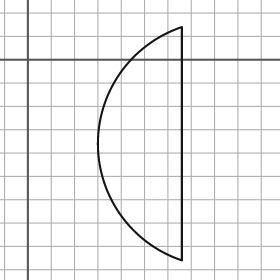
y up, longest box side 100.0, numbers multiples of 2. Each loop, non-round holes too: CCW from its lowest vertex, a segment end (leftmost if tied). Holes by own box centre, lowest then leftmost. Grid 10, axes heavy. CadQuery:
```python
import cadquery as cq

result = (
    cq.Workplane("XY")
    .moveTo(66.0, -86.0)
    .lineTo(66.0, 14.0)
    .threePointArc((30.0, -36.0), (66.0, -86.0))
    .close()
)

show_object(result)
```